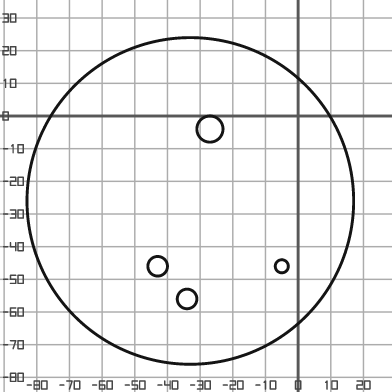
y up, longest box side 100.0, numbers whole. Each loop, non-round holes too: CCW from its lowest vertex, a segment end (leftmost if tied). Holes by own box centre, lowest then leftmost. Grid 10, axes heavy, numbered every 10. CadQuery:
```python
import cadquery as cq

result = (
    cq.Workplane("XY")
    .moveTo(-33.0, -26.0)
    .circle(50.0)
    .moveTo(-34.0, -56.0)
    .circle(3.0)
    .moveTo(-43.0, -46.0)
    .circle(3.0)
    .moveTo(-5.0, -46.0)
    .circle(2.0)
    .moveTo(-27.0, -4.0)
    .circle(4.0)
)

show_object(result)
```